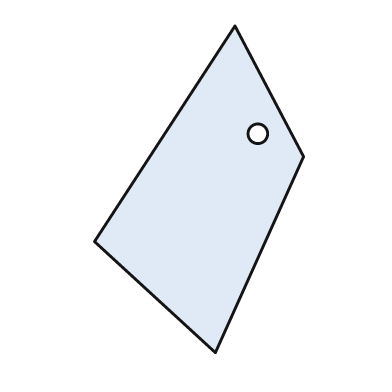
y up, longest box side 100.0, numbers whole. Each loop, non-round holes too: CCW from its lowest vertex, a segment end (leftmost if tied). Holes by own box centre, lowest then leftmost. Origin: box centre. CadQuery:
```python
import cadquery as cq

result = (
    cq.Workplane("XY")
    .moveTo(5.0, -50.0)
    .lineTo(32.0, 10.0)
    .lineTo(11.0, 50.0)
    .lineTo(-32.0, -16.0)
    .close()
    .moveTo(18.0, 17.0)
    .circle(3.0)
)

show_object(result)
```